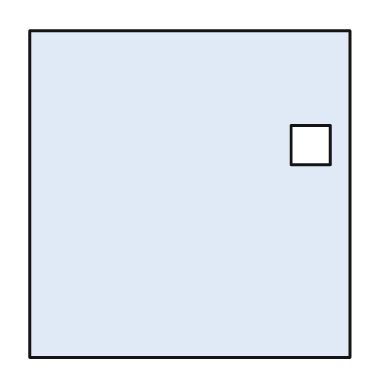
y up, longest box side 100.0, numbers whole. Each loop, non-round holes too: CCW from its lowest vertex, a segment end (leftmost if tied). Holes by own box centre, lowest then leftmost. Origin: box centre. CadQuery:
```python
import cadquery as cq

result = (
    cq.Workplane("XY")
    .moveTo(-49.0, -50.0)
    .lineTo(49.0, -50.0)
    .lineTo(49.0, 50.0)
    .lineTo(-49.0, 50.0)
    .close()
    .moveTo(31.0, 9.0)
    .lineTo(43.0, 9.0)
    .lineTo(43.0, 21.0)
    .lineTo(31.0, 21.0)
    .close()
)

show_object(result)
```